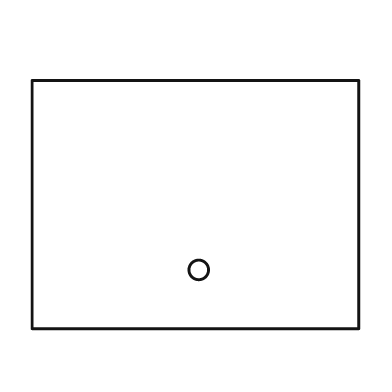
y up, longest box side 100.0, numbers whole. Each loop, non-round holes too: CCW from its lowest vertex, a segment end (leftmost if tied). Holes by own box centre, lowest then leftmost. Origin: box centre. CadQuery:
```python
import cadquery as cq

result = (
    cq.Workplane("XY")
    .moveTo(-50.0, -38.0)
    .lineTo(50.0, -38.0)
    .lineTo(50.0, 38.0)
    .lineTo(-50.0, 38.0)
    .close()
    .moveTo(1.0, -20.0)
    .circle(3.0)
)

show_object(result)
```